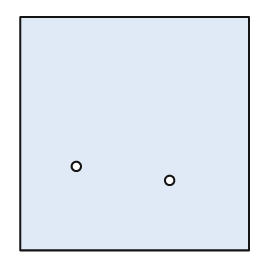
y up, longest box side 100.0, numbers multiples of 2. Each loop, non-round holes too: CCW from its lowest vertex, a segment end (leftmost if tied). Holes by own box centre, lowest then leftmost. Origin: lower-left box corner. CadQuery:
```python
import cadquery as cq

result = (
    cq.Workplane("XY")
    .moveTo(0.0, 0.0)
    .lineTo(98.0, 0.0)
    .lineTo(98.0, 100.0)
    .lineTo(0.0, 100.0)
    .close()
    .moveTo(64.0, 30.0)
    .circle(2.0)
    .moveTo(24.0, 36.0)
    .circle(2.0)
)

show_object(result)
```